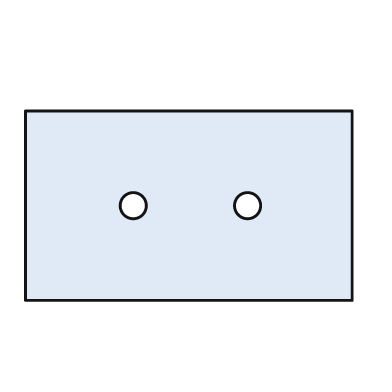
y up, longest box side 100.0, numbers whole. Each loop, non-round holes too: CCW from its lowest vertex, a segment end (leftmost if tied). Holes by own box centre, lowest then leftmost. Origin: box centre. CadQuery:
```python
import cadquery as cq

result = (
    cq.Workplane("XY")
    .moveTo(-50.0, -29.0)
    .lineTo(50.0, -29.0)
    .lineTo(50.0, 29.0)
    .lineTo(-50.0, 29.0)
    .close()
    .moveTo(-17.0, 0.0)
    .circle(4.0)
    .moveTo(18.0, 0.0)
    .circle(4.0)
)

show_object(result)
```